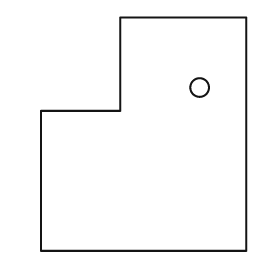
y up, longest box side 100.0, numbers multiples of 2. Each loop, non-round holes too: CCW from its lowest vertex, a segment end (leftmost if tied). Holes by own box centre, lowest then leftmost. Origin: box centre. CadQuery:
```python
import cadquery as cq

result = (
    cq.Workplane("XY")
    .moveTo(-44.0, -50.0)
    .lineTo(44.0, -50.0)
    .lineTo(44.0, 50.0)
    .lineTo(-10.0, 50.0)
    .lineTo(-10.0, 10.0)
    .lineTo(-44.0, 10.0)
    .close()
    .moveTo(24.0, 20.0)
    .circle(4.0)
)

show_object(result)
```